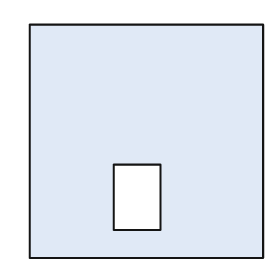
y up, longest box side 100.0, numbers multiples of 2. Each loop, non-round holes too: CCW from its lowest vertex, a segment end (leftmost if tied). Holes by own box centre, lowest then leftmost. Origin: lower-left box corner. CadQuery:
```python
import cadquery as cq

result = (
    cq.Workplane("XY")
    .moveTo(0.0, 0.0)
    .lineTo(100.0, 0.0)
    .lineTo(100.0, 100.0)
    .lineTo(0.0, 100.0)
    .close()
    .moveTo(36.0, 12.0)
    .lineTo(56.0, 12.0)
    .lineTo(56.0, 40.0)
    .lineTo(36.0, 40.0)
    .close()
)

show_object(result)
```